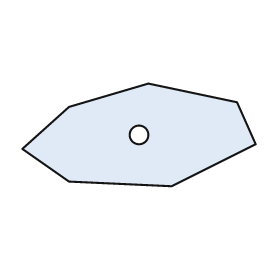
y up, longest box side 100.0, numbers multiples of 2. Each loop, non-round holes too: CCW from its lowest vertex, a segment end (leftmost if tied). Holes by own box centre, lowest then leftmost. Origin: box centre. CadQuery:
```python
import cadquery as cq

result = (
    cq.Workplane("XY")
    .moveTo(14.0, -22.0)
    .lineTo(50.0, -4.0)
    .lineTo(42.0, 14.0)
    .lineTo(4.0, 22.0)
    .lineTo(-30.0, 12.0)
    .lineTo(-50.0, -6.0)
    .lineTo(-30.0, -20.0)
    .close()
    .moveTo(0.0, 0.0)
    .circle(4.0)
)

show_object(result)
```